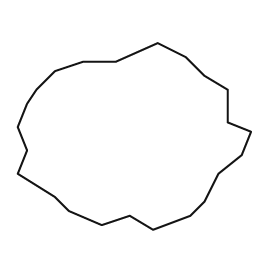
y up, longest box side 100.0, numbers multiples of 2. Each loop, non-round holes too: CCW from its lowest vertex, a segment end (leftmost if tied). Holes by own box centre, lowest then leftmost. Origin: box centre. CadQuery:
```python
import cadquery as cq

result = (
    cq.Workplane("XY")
    .moveTo(8.0, -40.0)
    .lineTo(24.0, -34.0)
    .lineTo(30.0, -28.0)
    .lineTo(36.0, -16.0)
    .lineTo(46.0, -8.0)
    .lineTo(50.0, 2.0)
    .lineTo(40.0, 6.0)
    .lineTo(40.0, 20.0)
    .lineTo(30.0, 26.0)
    .lineTo(22.0, 34.0)
    .lineTo(10.0, 40.0)
    .lineTo(-8.0, 32.0)
    .lineTo(-22.0, 32.0)
    .lineTo(-34.0, 28.0)
    .lineTo(-42.0, 20.0)
    .lineTo(-46.0, 14.0)
    .lineTo(-50.0, 4.0)
    .lineTo(-46.0, -6.0)
    .lineTo(-50.0, -16.0)
    .lineTo(-34.0, -26.0)
    .lineTo(-28.0, -32.0)
    .lineTo(-14.0, -38.0)
    .lineTo(-2.0, -34.0)
    .close()
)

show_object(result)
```